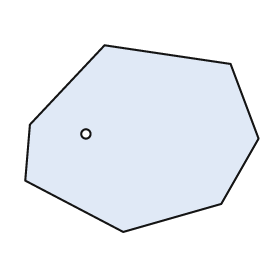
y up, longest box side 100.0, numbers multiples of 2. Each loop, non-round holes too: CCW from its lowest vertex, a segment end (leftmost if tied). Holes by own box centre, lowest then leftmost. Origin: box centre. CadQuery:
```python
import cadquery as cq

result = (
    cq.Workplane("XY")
    .moveTo(-8.0, -40.0)
    .lineTo(34.0, -28.0)
    .lineTo(50.0, 0.0)
    .lineTo(38.0, 32.0)
    .lineTo(-16.0, 40.0)
    .lineTo(-48.0, 6.0)
    .lineTo(-50.0, -18.0)
    .close()
    .moveTo(-24.0, 2.0)
    .circle(2.0)
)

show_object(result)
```